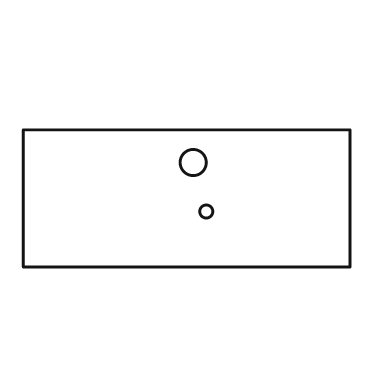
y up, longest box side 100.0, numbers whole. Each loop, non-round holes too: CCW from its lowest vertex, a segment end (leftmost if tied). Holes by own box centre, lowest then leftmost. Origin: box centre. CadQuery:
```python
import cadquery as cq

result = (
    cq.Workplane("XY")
    .moveTo(-50.0, -21.0)
    .lineTo(50.0, -21.0)
    .lineTo(50.0, 21.0)
    .lineTo(-50.0, 21.0)
    .close()
    .moveTo(6.0, -4.0)
    .circle(2.0)
    .moveTo(2.0, 11.0)
    .circle(4.0)
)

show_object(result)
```